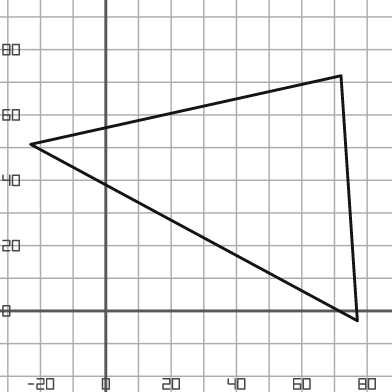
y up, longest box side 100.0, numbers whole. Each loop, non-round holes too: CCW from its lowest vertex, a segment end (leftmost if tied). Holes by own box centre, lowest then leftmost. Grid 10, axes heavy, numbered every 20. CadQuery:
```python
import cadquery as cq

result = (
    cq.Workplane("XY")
    .moveTo(77.0, -3.0)
    .lineTo(72.0, 72.0)
    .lineTo(-23.0, 51.0)
    .close()
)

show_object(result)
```